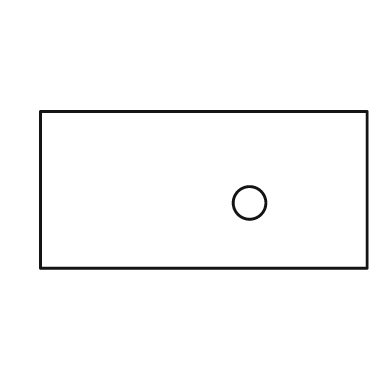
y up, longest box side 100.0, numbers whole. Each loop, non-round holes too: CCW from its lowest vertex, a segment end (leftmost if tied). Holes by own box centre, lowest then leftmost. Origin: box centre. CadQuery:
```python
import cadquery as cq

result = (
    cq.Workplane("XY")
    .moveTo(-50.0, -24.0)
    .lineTo(50.0, -24.0)
    .lineTo(50.0, 24.0)
    .lineTo(-50.0, 24.0)
    .close()
    .moveTo(14.0, -4.0)
    .circle(5.0)
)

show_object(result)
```